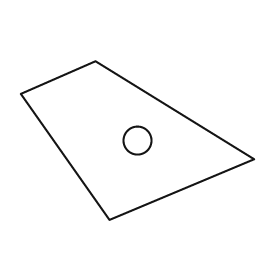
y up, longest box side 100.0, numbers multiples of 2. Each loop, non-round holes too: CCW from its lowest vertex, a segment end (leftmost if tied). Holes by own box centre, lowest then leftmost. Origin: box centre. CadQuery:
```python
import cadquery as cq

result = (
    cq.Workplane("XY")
    .moveTo(-12.0, -34.0)
    .lineTo(50.0, -8.0)
    .lineTo(-18.0, 34.0)
    .lineTo(-50.0, 20.0)
    .close()
    .moveTo(0.0, 0.0)
    .circle(6.0)
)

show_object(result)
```